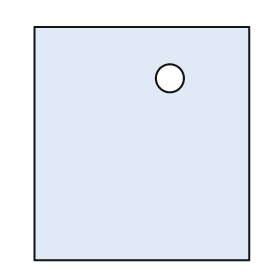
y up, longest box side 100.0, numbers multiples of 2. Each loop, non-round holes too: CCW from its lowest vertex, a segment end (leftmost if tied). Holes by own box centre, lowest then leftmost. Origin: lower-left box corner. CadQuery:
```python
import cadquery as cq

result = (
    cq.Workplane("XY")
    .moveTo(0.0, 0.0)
    .lineTo(92.0, 0.0)
    .lineTo(92.0, 100.0)
    .lineTo(0.0, 100.0)
    .close()
    .moveTo(58.0, 78.0)
    .circle(6.0)
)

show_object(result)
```